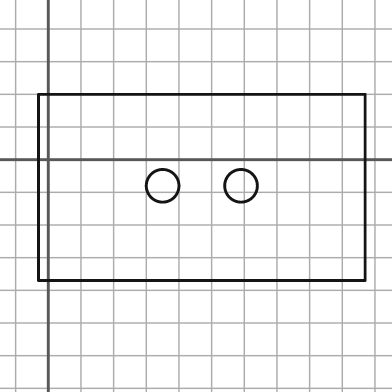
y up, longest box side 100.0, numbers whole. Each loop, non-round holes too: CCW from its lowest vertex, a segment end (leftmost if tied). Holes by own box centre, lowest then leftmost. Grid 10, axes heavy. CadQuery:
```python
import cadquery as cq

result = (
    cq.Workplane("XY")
    .moveTo(-3.0, -37.0)
    .lineTo(97.0, -37.0)
    .lineTo(97.0, 20.0)
    .lineTo(-3.0, 20.0)
    .close()
    .moveTo(35.0, -8.0)
    .circle(5.0)
    .moveTo(59.0, -8.0)
    .circle(5.0)
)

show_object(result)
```